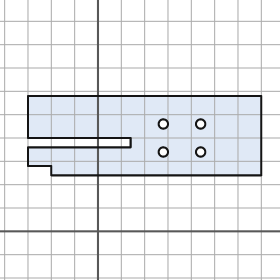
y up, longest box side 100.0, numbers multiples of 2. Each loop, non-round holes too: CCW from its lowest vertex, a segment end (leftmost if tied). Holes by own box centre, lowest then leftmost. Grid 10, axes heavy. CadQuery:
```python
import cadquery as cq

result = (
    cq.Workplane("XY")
    .moveTo(-20.0, 24.0)
    .lineTo(70.0, 24.0)
    .lineTo(70.0, 58.0)
    .lineTo(-30.0, 58.0)
    .lineTo(-30.0, 40.0)
    .lineTo(14.0, 40.0)
    .lineTo(14.0, 36.0)
    .lineTo(-30.0, 36.0)
    .lineTo(-30.0, 28.0)
    .lineTo(-20.0, 28.0)
    .close()
    .moveTo(28.0, 34.0)
    .circle(2.0)
    .moveTo(44.0, 34.0)
    .circle(2.0)
    .moveTo(28.0, 46.0)
    .circle(2.0)
    .moveTo(44.0, 46.0)
    .circle(2.0)
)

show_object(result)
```